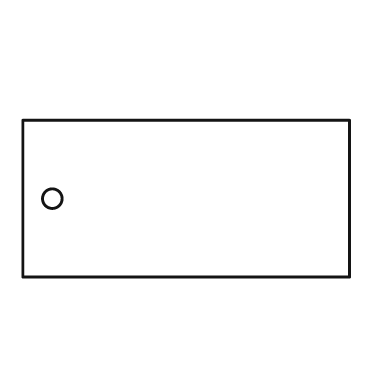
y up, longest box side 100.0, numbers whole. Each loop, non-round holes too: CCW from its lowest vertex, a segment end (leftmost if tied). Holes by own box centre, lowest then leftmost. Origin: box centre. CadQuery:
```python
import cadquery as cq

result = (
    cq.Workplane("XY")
    .moveTo(-50.0, -24.0)
    .lineTo(50.0, -24.0)
    .lineTo(50.0, 24.0)
    .lineTo(-50.0, 24.0)
    .close()
    .moveTo(-41.0, 0.0)
    .circle(3.0)
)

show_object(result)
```